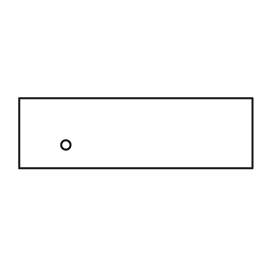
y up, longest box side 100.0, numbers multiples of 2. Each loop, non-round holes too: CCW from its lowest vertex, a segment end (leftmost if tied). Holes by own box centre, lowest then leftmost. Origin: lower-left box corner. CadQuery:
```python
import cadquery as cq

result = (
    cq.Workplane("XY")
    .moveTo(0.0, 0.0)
    .lineTo(100.0, 0.0)
    .lineTo(100.0, 30.0)
    .lineTo(0.0, 30.0)
    .close()
    .moveTo(20.0, 10.0)
    .circle(2.0)
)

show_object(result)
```